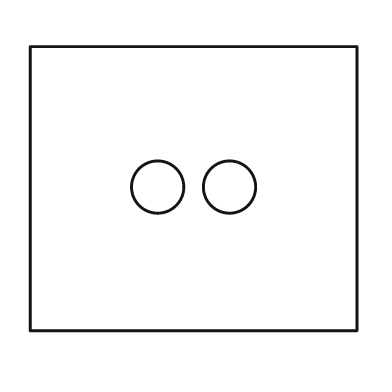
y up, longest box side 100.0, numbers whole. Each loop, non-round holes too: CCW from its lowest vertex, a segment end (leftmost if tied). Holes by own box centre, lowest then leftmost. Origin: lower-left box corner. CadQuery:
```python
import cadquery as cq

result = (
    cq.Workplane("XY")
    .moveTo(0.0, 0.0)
    .lineTo(100.0, 0.0)
    .lineTo(100.0, 87.0)
    .lineTo(0.0, 87.0)
    .close()
    .moveTo(39.0, 44.0)
    .circle(8.0)
    .moveTo(61.0, 44.0)
    .circle(8.0)
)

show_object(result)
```